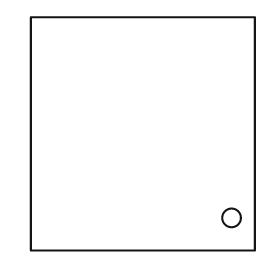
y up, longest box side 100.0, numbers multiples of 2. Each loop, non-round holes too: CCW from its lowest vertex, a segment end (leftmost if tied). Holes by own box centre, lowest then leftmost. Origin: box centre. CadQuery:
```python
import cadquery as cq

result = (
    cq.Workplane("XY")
    .moveTo(-48.0, -50.0)
    .lineTo(48.0, -50.0)
    .lineTo(48.0, 50.0)
    .lineTo(-48.0, 50.0)
    .close()
    .moveTo(38.0, -36.0)
    .circle(4.0)
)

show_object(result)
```